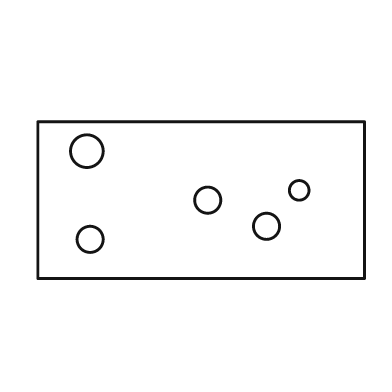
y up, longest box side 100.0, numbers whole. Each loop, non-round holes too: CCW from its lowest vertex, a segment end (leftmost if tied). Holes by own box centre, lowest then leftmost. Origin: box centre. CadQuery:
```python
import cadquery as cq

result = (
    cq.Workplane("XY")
    .moveTo(-50.0, -24.0)
    .lineTo(50.0, -24.0)
    .lineTo(50.0, 24.0)
    .lineTo(-50.0, 24.0)
    .close()
    .moveTo(-34.0, -12.0)
    .circle(4.0)
    .moveTo(20.0, -8.0)
    .circle(4.0)
    .moveTo(2.0, 0.0)
    .circle(4.0)
    .moveTo(30.0, 3.0)
    .circle(3.0)
    .moveTo(-35.0, 15.0)
    .circle(5.0)
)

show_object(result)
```